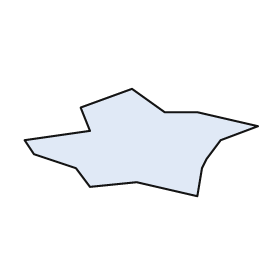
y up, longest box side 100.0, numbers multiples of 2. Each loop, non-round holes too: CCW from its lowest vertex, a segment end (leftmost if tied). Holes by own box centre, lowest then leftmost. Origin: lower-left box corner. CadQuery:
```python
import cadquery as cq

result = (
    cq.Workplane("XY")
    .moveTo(74.0, 0.0)
    .lineTo(76.0, 12.0)
    .lineTo(78.0, 16.0)
    .lineTo(84.0, 24.0)
    .lineTo(100.0, 30.0)
    .lineTo(74.0, 36.0)
    .lineTo(60.0, 36.0)
    .lineTo(46.0, 46.0)
    .lineTo(24.0, 38.0)
    .lineTo(28.0, 28.0)
    .lineTo(0.0, 24.0)
    .lineTo(4.0, 18.0)
    .lineTo(22.0, 12.0)
    .lineTo(28.0, 4.0)
    .lineTo(48.0, 6.0)
    .close()
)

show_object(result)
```